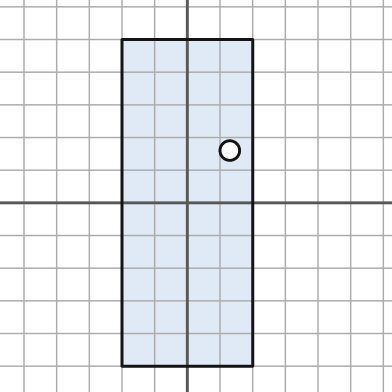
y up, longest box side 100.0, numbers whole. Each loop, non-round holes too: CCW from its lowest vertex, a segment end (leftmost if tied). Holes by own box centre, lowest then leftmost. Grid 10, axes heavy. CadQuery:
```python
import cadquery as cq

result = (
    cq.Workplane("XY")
    .moveTo(-20.0, -50.0)
    .lineTo(20.0, -50.0)
    .lineTo(20.0, 50.0)
    .lineTo(-20.0, 50.0)
    .close()
    .moveTo(13.0, 16.0)
    .circle(3.0)
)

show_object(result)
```